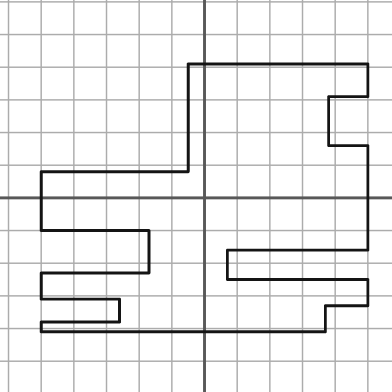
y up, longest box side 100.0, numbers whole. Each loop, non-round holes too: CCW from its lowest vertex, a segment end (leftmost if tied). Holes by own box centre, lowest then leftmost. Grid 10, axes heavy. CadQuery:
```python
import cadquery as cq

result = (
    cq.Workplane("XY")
    .moveTo(-50.0, -41.0)
    .lineTo(37.0, -41.0)
    .lineTo(37.0, -33.0)
    .lineTo(50.0, -33.0)
    .lineTo(50.0, -25.0)
    .lineTo(7.0, -25.0)
    .lineTo(7.0, -16.0)
    .lineTo(50.0, -16.0)
    .lineTo(50.0, 16.0)
    .lineTo(38.0, 16.0)
    .lineTo(38.0, 31.0)
    .lineTo(50.0, 31.0)
    .lineTo(50.0, 41.0)
    .lineTo(-5.0, 41.0)
    .lineTo(-5.0, 8.0)
    .lineTo(-50.0, 8.0)
    .lineTo(-50.0, -10.0)
    .lineTo(-17.0, -10.0)
    .lineTo(-17.0, -23.0)
    .lineTo(-50.0, -23.0)
    .lineTo(-50.0, -31.0)
    .lineTo(-26.0, -31.0)
    .lineTo(-26.0, -38.0)
    .lineTo(-50.0, -38.0)
    .close()
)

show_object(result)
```